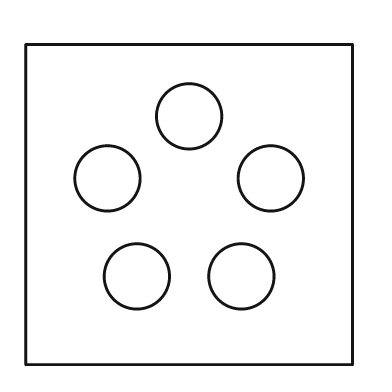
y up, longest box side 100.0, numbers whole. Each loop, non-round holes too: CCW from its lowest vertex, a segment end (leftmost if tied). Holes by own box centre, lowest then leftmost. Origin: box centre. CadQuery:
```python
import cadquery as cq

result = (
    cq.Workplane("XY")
    .moveTo(-50.0, -49.0)
    .lineTo(50.0, -49.0)
    .lineTo(50.0, 49.0)
    .lineTo(-50.0, 49.0)
    .close()
    .moveTo(-16.0, -22.0)
    .circle(10.0)
    .moveTo(16.0, -22.0)
    .circle(10.0)
    .moveTo(-25.0, 8.0)
    .circle(10.0)
    .moveTo(25.0, 8.0)
    .circle(10.0)
    .moveTo(0.0, 27.0)
    .circle(10.0)
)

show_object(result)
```